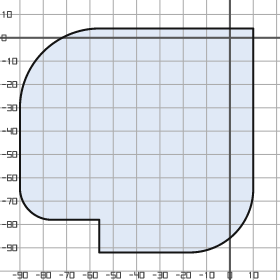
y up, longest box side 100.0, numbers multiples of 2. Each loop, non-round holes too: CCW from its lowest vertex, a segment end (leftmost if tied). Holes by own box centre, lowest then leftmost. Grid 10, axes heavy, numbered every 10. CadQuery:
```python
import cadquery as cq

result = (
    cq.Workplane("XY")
    .moveTo(-56.0, -92.0)
    .lineTo(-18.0, -92.0)
    .threePointArc((2.0, -84.0), (10.0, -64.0))
    .lineTo(10.0, 4.0)
    .lineTo(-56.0, 4.0)
    .threePointArc((-80.0, -6.0), (-90.0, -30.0))
    .lineTo(-90.0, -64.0)
    .threePointArc((-86.0, -74.0), (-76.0, -78.0))
    .lineTo(-56.0, -78.0)
    .close()
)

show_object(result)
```